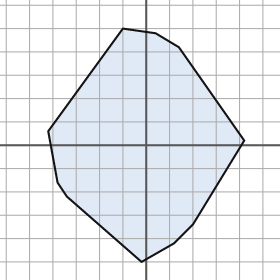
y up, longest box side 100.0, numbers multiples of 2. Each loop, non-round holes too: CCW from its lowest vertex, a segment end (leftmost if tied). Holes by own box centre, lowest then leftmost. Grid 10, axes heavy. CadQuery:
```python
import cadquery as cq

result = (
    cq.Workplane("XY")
    .moveTo(-2.0, -50.0)
    .lineTo(12.0, -42.0)
    .lineTo(20.0, -34.0)
    .lineTo(42.0, 2.0)
    .lineTo(14.0, 42.0)
    .lineTo(4.0, 48.0)
    .lineTo(-10.0, 50.0)
    .lineTo(-42.0, 6.0)
    .lineTo(-38.0, -16.0)
    .lineTo(-34.0, -22.0)
    .close()
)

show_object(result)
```